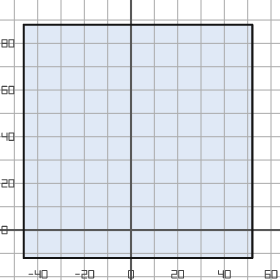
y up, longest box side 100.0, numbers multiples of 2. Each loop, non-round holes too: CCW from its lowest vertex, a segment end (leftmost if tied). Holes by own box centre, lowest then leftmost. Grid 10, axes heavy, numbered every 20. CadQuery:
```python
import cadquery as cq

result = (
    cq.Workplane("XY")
    .moveTo(-46.0, -12.0)
    .lineTo(52.0, -12.0)
    .lineTo(52.0, 88.0)
    .lineTo(-46.0, 88.0)
    .close()
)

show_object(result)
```